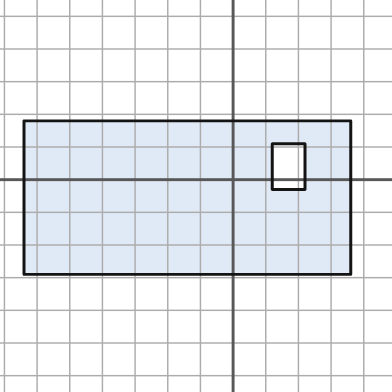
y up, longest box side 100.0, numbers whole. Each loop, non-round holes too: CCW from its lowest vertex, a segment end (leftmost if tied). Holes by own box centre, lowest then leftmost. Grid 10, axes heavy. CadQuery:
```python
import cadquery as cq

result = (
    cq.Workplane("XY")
    .moveTo(-64.0, -29.0)
    .lineTo(36.0, -29.0)
    .lineTo(36.0, 18.0)
    .lineTo(-64.0, 18.0)
    .close()
    .moveTo(12.0, -3.0)
    .lineTo(22.0, -3.0)
    .lineTo(22.0, 11.0)
    .lineTo(12.0, 11.0)
    .close()
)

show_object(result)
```